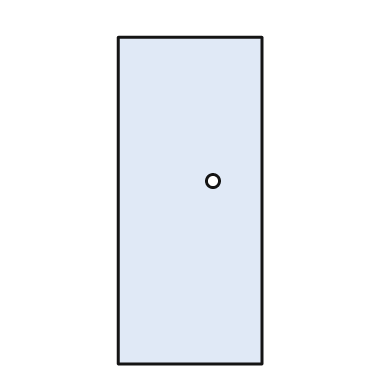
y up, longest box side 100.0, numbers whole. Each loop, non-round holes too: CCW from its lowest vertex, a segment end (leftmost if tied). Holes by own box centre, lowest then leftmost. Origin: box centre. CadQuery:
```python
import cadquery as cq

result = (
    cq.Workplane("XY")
    .moveTo(-22.0, -50.0)
    .lineTo(22.0, -50.0)
    .lineTo(22.0, 50.0)
    .lineTo(-22.0, 50.0)
    .close()
    .moveTo(7.0, 6.0)
    .circle(2.0)
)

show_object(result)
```